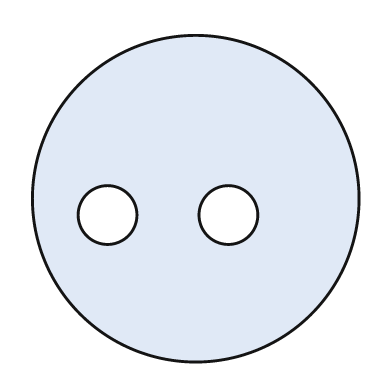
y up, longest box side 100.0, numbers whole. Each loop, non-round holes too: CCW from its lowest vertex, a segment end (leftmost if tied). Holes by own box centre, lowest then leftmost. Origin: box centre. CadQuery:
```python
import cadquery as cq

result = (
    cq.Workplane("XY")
    .moveTo(0.0, 0.0)
    .circle(50.0)
    .moveTo(-27.0, -5.0)
    .circle(9.0)
    .moveTo(10.0, -5.0)
    .circle(9.0)
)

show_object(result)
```